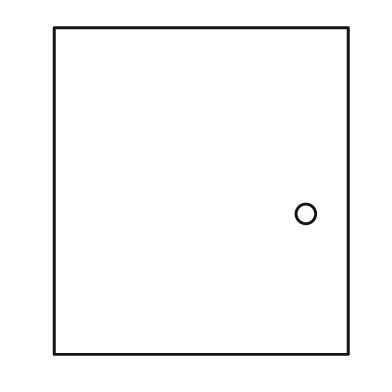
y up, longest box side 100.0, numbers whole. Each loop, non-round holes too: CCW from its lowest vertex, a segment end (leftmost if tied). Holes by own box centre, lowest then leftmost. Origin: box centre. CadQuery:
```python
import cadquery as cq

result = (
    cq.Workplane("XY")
    .moveTo(-45.0, -50.0)
    .lineTo(45.0, -50.0)
    .lineTo(45.0, 50.0)
    .lineTo(-45.0, 50.0)
    .close()
    .moveTo(32.0, -7.0)
    .circle(3.0)
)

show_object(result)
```